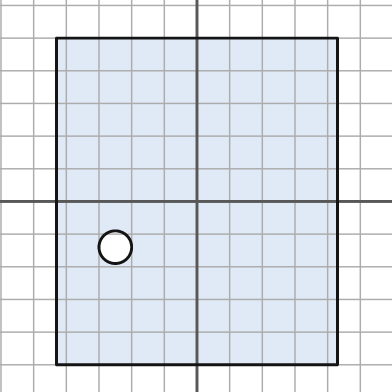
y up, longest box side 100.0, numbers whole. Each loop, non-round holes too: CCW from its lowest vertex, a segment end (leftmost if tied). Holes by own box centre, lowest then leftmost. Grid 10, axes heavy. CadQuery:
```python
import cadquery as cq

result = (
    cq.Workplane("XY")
    .moveTo(-43.0, -50.0)
    .lineTo(43.0, -50.0)
    .lineTo(43.0, 50.0)
    .lineTo(-43.0, 50.0)
    .close()
    .moveTo(-25.0, -14.0)
    .circle(5.0)
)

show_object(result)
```